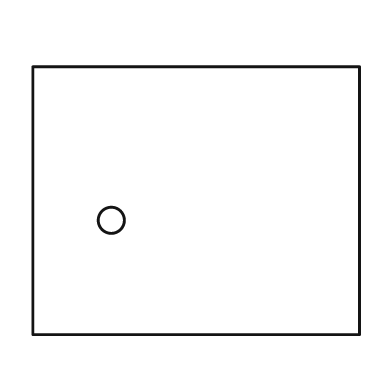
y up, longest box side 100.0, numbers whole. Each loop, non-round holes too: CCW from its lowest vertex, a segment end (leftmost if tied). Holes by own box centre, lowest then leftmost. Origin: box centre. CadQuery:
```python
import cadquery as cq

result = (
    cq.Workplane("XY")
    .moveTo(-50.0, -41.0)
    .lineTo(50.0, -41.0)
    .lineTo(50.0, 41.0)
    .lineTo(-50.0, 41.0)
    .close()
    .moveTo(-26.0, -6.0)
    .circle(4.0)
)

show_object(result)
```